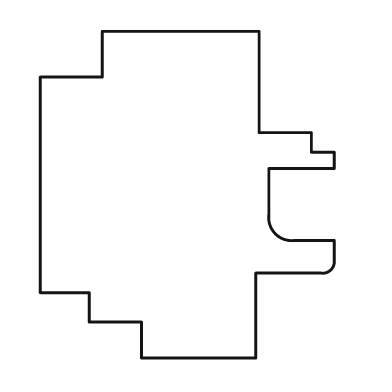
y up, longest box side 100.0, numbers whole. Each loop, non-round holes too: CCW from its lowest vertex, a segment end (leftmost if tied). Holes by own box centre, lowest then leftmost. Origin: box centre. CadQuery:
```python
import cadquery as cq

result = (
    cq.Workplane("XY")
    .moveTo(-14.0, -50.0)
    .lineTo(21.0, -50.0)
    .lineTo(21.0, -24.0)
    .lineTo(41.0, -24.0)
    .threePointArc((44.0, -23.0), (45.0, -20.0))
    .lineTo(45.0, -14.0)
    .lineTo(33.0, -14.0)
    .threePointArc((27.0, -12.0), (25.0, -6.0))
    .lineTo(25.0, 8.0)
    .lineTo(45.0, 8.0)
    .lineTo(45.0, 13.0)
    .lineTo(38.0, 13.0)
    .lineTo(38.0, 19.0)
    .lineTo(22.0, 19.0)
    .lineTo(22.0, 50.0)
    .lineTo(-26.0, 50.0)
    .lineTo(-26.0, 36.0)
    .lineTo(-45.0, 36.0)
    .lineTo(-45.0, -30.0)
    .lineTo(-30.0, -30.0)
    .lineTo(-30.0, -39.0)
    .lineTo(-14.0, -39.0)
    .close()
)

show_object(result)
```